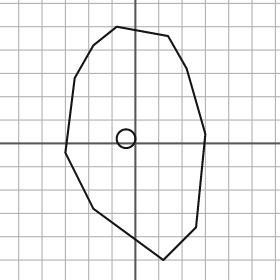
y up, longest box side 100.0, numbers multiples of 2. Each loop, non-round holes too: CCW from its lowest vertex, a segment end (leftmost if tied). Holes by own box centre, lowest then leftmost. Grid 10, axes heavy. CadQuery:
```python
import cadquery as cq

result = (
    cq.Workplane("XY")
    .moveTo(12.0, -50.0)
    .lineTo(26.0, -36.0)
    .lineTo(30.0, 4.0)
    .lineTo(22.0, 32.0)
    .lineTo(14.0, 46.0)
    .lineTo(-8.0, 50.0)
    .lineTo(-18.0, 42.0)
    .lineTo(-26.0, 28.0)
    .lineTo(-30.0, -4.0)
    .lineTo(-18.0, -28.0)
    .close()
    .moveTo(-4.0, 2.0)
    .circle(4.0)
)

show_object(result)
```